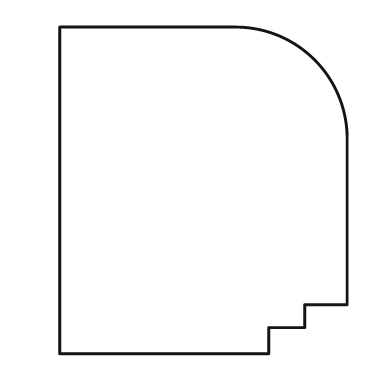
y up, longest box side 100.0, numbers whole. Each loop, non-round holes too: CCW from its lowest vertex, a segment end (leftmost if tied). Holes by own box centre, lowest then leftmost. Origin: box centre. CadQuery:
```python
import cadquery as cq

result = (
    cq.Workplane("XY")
    .moveTo(-44.0, -50.0)
    .lineTo(20.0, -50.0)
    .lineTo(20.0, -42.0)
    .lineTo(31.0, -42.0)
    .lineTo(31.0, -35.0)
    .lineTo(44.0, -35.0)
    .lineTo(44.0, 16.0)
    .threePointArc((34.0, 40.0), (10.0, 50.0))
    .lineTo(-44.0, 50.0)
    .close()
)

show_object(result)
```